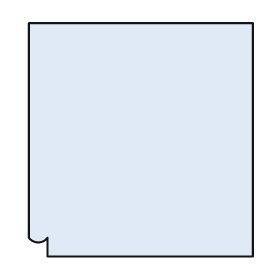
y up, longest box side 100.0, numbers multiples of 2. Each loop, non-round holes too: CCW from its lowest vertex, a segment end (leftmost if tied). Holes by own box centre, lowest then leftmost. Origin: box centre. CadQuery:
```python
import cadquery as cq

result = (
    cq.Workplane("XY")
    .moveTo(-40.0, -50.0)
    .lineTo(48.0, -50.0)
    .lineTo(48.0, 50.0)
    .lineTo(-48.0, 50.0)
    .lineTo(-48.0, -42.0)
    .threePointArc((-44.0, -44.0), (-40.0, -42.0))
    .close()
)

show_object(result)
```